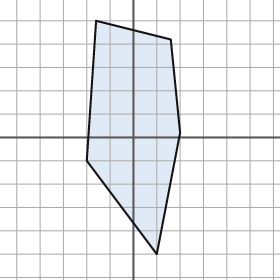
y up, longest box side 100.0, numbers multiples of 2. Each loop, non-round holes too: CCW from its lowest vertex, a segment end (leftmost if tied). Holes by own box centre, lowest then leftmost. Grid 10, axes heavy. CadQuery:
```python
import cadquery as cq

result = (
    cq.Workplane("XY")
    .moveTo(10.0, -50.0)
    .lineTo(20.0, 2.0)
    .lineTo(16.0, 42.0)
    .lineTo(-16.0, 50.0)
    .lineTo(-20.0, -10.0)
    .close()
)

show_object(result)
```